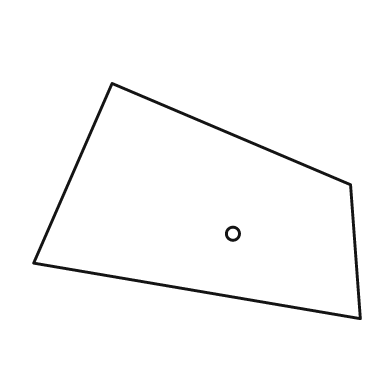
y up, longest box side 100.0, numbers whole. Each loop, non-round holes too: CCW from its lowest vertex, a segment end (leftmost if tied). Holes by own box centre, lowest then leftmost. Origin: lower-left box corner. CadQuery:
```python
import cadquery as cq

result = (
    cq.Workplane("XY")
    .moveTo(100.0, 0.0)
    .lineTo(97.0, 41.0)
    .lineTo(24.0, 72.0)
    .lineTo(0.0, 17.0)
    .close()
    .moveTo(61.0, 26.0)
    .circle(2.0)
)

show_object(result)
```